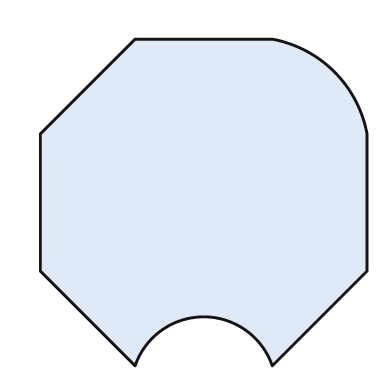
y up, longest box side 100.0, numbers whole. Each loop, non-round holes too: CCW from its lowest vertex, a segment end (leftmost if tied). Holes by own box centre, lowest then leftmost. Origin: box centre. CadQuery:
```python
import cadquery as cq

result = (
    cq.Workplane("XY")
    .moveTo(-21.0, -50.0)
    .threePointArc((0.0, -35.0), (21.0, -50.0))
    .lineTo(50.0, -21.0)
    .lineTo(50.0, 21.0)
    .threePointArc((40.0, 40.0), (21.0, 50.0))
    .lineTo(-21.0, 50.0)
    .lineTo(-50.0, 21.0)
    .lineTo(-50.0, -21.0)
    .close()
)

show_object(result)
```